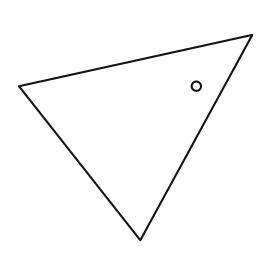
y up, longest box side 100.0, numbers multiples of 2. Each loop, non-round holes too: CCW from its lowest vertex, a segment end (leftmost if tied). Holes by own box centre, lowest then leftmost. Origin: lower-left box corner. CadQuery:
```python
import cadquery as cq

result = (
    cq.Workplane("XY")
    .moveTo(52.0, 0.0)
    .lineTo(100.0, 88.0)
    .lineTo(0.0, 66.0)
    .close()
    .moveTo(76.0, 66.0)
    .circle(2.0)
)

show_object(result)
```